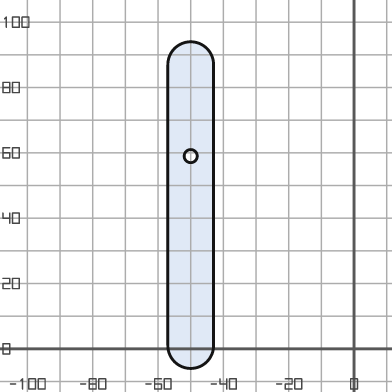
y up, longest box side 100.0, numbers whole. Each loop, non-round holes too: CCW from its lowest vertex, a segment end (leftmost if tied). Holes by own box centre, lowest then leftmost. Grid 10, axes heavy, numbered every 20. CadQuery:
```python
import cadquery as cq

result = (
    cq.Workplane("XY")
    .moveTo(-57.0, 1.0)
    .threePointArc((-50.0, -6.0), (-43.0, 1.0))
    .lineTo(-43.0, 87.0)
    .threePointArc((-50.0, 94.0), (-57.0, 87.0))
    .close()
    .moveTo(-50.0, 59.0)
    .circle(2.0)
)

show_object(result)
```